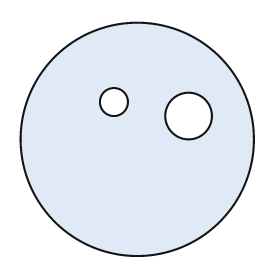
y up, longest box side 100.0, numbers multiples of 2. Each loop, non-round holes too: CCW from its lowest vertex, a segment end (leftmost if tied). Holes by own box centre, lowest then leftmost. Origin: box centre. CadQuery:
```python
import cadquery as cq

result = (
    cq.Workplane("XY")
    .moveTo(0.0, 0.0)
    .circle(50.0)
    .moveTo(22.0, 10.0)
    .circle(10.0)
    .moveTo(-10.0, 16.0)
    .circle(6.0)
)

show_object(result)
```